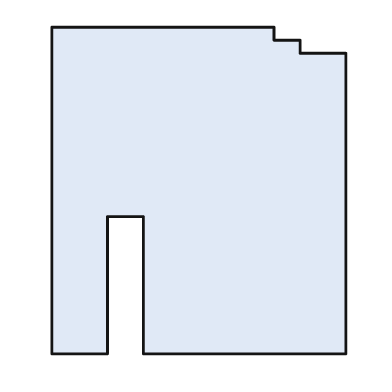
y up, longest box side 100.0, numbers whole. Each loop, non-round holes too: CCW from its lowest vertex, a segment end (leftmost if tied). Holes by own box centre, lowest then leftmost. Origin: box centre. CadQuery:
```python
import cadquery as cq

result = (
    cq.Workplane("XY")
    .moveTo(-45.0, -50.0)
    .lineTo(-28.0, -50.0)
    .lineTo(-28.0, -8.0)
    .lineTo(-17.0, -8.0)
    .lineTo(-17.0, -50.0)
    .lineTo(45.0, -50.0)
    .lineTo(45.0, 42.0)
    .lineTo(31.0, 42.0)
    .lineTo(31.0, 46.0)
    .lineTo(23.0, 46.0)
    .lineTo(23.0, 50.0)
    .lineTo(-45.0, 50.0)
    .close()
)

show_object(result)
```